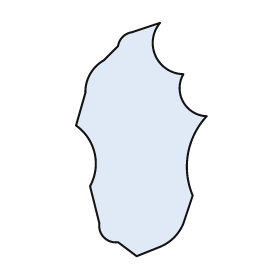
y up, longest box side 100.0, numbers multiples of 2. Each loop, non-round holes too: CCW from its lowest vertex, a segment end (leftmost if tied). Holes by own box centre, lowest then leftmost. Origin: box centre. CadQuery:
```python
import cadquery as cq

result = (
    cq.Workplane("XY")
    .moveTo(-2.0, -50.0)
    .lineTo(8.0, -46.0)
    .threePointArc((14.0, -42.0), (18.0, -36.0))
    .lineTo(22.0, -24.0)
    .threePointArc((20.0, -6.0), (28.0, 10.0))
    .threePointArc((18.0, 16.0), (18.0, 28.0))
    .threePointArc((6.0, 36.0), (8.0, 50.0))
    .lineTo(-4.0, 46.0)
    .threePointArc((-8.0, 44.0), (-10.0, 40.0))
    .lineTo(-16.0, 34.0)
    .threePointArc((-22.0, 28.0), (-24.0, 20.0))
    .lineTo(-28.0, 6.0)
    .threePointArc((-20.0, -6.0), (-22.0, -20.0))
    .lineTo(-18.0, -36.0)
    .threePointArc((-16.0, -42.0), (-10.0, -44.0))
    .close()
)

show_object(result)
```